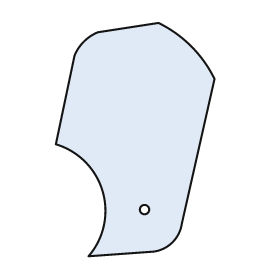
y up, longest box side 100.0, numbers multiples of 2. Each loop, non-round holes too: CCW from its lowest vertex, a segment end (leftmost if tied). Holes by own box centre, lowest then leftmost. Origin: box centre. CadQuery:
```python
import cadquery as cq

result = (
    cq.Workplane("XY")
    .moveTo(-20.0, -50.0)
    .lineTo(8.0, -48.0)
    .threePointArc((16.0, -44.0), (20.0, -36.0))
    .lineTo(34.0, 26.0)
    .threePointArc((24.0, 40.0), (10.0, 50.0))
    .lineTo(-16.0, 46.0)
    .threePointArc((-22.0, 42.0), (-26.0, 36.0))
    .lineTo(-34.0, -2.0)
    .threePointArc((-14.0, -22.0), (-20.0, -50.0))
    .close()
    .moveTo(4.0, -30.0)
    .circle(2.0)
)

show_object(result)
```